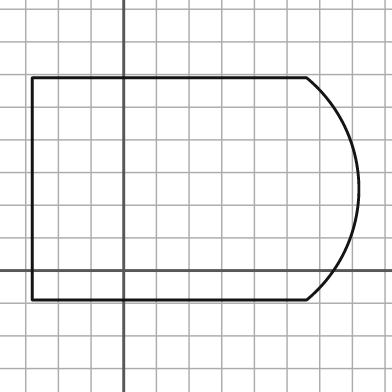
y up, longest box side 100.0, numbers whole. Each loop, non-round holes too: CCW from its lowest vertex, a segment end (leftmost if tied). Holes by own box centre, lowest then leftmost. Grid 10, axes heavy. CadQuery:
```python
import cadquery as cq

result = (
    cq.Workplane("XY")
    .moveTo(-28.0, -9.0)
    .lineTo(56.0, -9.0)
    .threePointArc((72.0, 25.0), (56.0, 59.0))
    .lineTo(-28.0, 59.0)
    .close()
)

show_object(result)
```